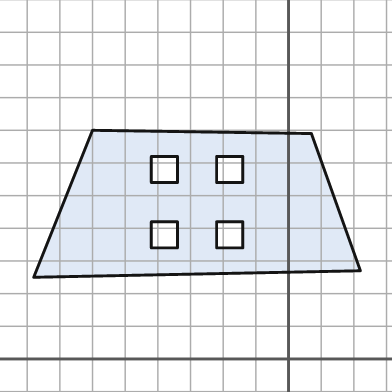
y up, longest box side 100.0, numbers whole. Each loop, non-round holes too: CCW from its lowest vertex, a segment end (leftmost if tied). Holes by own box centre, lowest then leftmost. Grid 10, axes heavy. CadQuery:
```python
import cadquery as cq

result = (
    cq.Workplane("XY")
    .moveTo(-78.0, 25.0)
    .lineTo(22.0, 27.0)
    .lineTo(7.0, 69.0)
    .lineTo(-60.0, 70.0)
    .close()
    .moveTo(-42.0, 34.0)
    .lineTo(-34.0, 34.0)
    .lineTo(-34.0, 42.0)
    .lineTo(-42.0, 42.0)
    .close()
    .moveTo(-22.0, 34.0)
    .lineTo(-14.0, 34.0)
    .lineTo(-14.0, 42.0)
    .lineTo(-22.0, 42.0)
    .close()
    .moveTo(-42.0, 54.0)
    .lineTo(-34.0, 54.0)
    .lineTo(-34.0, 62.0)
    .lineTo(-42.0, 62.0)
    .close()
    .moveTo(-22.0, 54.0)
    .lineTo(-14.0, 54.0)
    .lineTo(-14.0, 62.0)
    .lineTo(-22.0, 62.0)
    .close()
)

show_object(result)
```